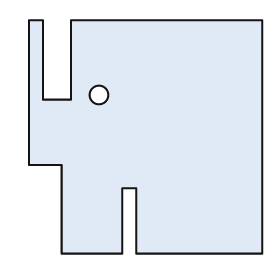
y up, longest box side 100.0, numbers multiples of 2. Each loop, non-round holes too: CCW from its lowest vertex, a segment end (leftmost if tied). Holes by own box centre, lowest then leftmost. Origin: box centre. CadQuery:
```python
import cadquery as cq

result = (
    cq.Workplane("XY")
    .moveTo(-36.0, -50.0)
    .lineTo(-10.0, -50.0)
    .lineTo(-10.0, -22.0)
    .lineTo(-4.0, -22.0)
    .lineTo(-4.0, -50.0)
    .lineTo(50.0, -50.0)
    .lineTo(50.0, 50.0)
    .lineTo(-32.0, 50.0)
    .lineTo(-32.0, 16.0)
    .lineTo(-44.0, 16.0)
    .lineTo(-44.0, 50.0)
    .lineTo(-50.0, 50.0)
    .lineTo(-50.0, -12.0)
    .lineTo(-36.0, -12.0)
    .close()
    .moveTo(-20.0, 18.0)
    .circle(4.0)
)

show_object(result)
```